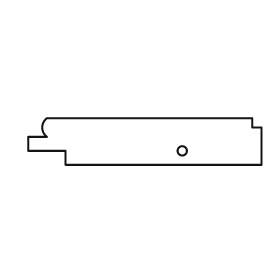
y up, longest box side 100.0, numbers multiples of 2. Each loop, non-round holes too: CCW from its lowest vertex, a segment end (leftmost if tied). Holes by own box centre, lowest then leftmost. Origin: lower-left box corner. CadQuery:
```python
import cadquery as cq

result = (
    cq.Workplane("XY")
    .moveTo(16.0, 0.0)
    .lineTo(100.0, 0.0)
    .lineTo(100.0, 16.0)
    .lineTo(96.0, 16.0)
    .lineTo(96.0, 20.0)
    .lineTo(8.0, 20.0)
    .threePointArc((6.0, 16.0), (8.0, 12.0))
    .lineTo(0.0, 12.0)
    .lineTo(0.0, 6.0)
    .lineTo(16.0, 6.0)
    .close()
    .moveTo(66.0, 6.0)
    .circle(2.0)
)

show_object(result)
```